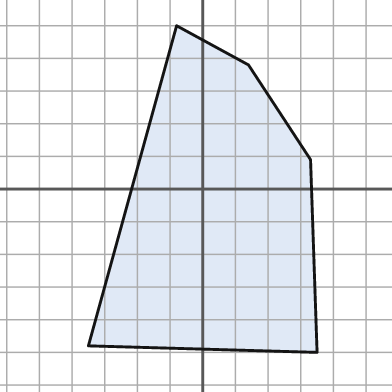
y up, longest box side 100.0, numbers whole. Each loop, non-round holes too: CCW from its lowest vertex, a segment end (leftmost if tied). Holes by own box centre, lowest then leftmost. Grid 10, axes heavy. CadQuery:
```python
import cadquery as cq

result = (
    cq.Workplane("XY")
    .moveTo(35.0, -50.0)
    .lineTo(33.0, 9.0)
    .lineTo(14.0, 38.0)
    .lineTo(-8.0, 50.0)
    .lineTo(-35.0, -48.0)
    .close()
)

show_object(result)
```